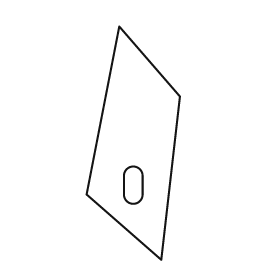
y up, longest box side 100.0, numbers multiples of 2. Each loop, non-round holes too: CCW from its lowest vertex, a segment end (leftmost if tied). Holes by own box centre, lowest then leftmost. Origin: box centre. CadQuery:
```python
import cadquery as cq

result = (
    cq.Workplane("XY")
    .moveTo(12.0, -50.0)
    .lineTo(20.0, 20.0)
    .lineTo(-6.0, 50.0)
    .lineTo(-20.0, -22.0)
    .close()
    .moveTo(-4.0, -22.0)
    .threePointArc((0.0, -26.0), (4.0, -22.0))
    .lineTo(4.0, -14.0)
    .threePointArc((0.0, -10.0), (-4.0, -14.0))
    .close()
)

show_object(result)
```